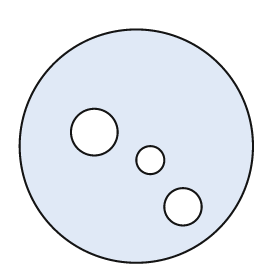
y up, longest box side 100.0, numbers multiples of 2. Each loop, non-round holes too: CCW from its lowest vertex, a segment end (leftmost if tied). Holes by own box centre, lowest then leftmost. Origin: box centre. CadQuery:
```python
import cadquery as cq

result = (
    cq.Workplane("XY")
    .moveTo(0.0, 0.0)
    .circle(50.0)
    .moveTo(20.0, -26.0)
    .circle(8.0)
    .moveTo(6.0, -6.0)
    .circle(6.0)
    .moveTo(-18.0, 6.0)
    .circle(10.0)
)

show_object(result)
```